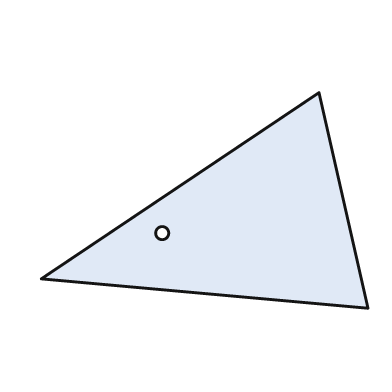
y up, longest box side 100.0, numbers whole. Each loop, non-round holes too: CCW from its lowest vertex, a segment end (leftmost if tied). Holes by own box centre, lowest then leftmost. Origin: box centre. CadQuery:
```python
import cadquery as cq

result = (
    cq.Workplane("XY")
    .moveTo(50.0, -33.0)
    .lineTo(35.0, 33.0)
    .lineTo(-50.0, -24.0)
    .close()
    .moveTo(-13.0, -10.0)
    .circle(2.0)
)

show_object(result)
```